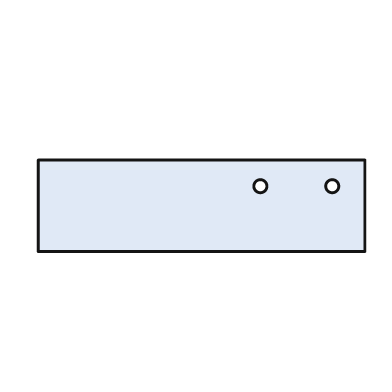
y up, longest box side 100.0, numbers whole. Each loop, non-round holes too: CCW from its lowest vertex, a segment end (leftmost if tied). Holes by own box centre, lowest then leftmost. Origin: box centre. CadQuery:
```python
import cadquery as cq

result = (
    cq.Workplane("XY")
    .moveTo(-50.0, -14.0)
    .lineTo(50.0, -14.0)
    .lineTo(50.0, 14.0)
    .lineTo(-50.0, 14.0)
    .close()
    .moveTo(18.0, 6.0)
    .circle(2.0)
    .moveTo(40.0, 6.0)
    .circle(2.0)
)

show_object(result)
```